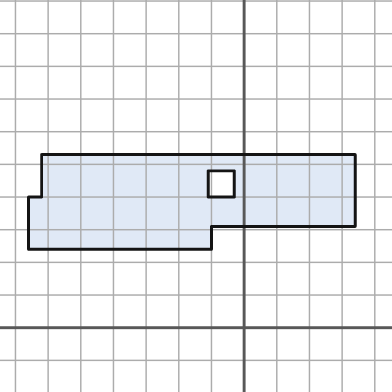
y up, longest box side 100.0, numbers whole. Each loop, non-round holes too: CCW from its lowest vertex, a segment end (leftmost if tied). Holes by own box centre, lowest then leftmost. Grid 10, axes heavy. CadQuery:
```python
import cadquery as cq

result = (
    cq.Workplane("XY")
    .moveTo(-66.0, 24.0)
    .lineTo(-10.0, 24.0)
    .lineTo(-10.0, 31.0)
    .lineTo(34.0, 31.0)
    .lineTo(34.0, 53.0)
    .lineTo(-62.0, 53.0)
    .lineTo(-62.0, 40.0)
    .lineTo(-66.0, 40.0)
    .close()
    .moveTo(-11.0, 40.0)
    .lineTo(-3.0, 40.0)
    .lineTo(-3.0, 48.0)
    .lineTo(-11.0, 48.0)
    .close()
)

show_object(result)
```